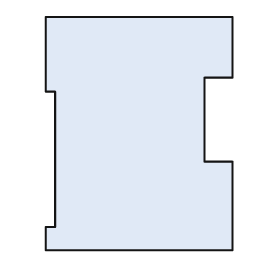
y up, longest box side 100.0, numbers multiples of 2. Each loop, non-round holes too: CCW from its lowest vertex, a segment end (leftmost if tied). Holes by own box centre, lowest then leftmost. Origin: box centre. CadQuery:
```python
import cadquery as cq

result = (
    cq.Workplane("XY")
    .moveTo(-40.0, -50.0)
    .lineTo(40.0, -50.0)
    .lineTo(40.0, -12.0)
    .lineTo(28.0, -12.0)
    .lineTo(28.0, 24.0)
    .lineTo(40.0, 24.0)
    .lineTo(40.0, 50.0)
    .lineTo(-40.0, 50.0)
    .lineTo(-40.0, 18.0)
    .lineTo(-36.0, 18.0)
    .lineTo(-36.0, -40.0)
    .lineTo(-40.0, -40.0)
    .close()
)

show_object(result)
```